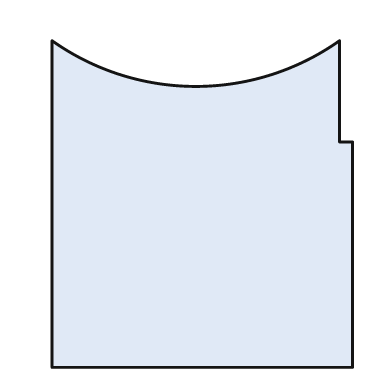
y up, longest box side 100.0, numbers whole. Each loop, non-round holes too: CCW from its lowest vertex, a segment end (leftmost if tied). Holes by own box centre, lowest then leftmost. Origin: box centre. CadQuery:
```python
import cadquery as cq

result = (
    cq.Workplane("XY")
    .moveTo(-46.0, -50.0)
    .lineTo(46.0, -50.0)
    .lineTo(46.0, 19.0)
    .lineTo(42.0, 19.0)
    .lineTo(42.0, 50.0)
    .threePointArc((-2.0, 36.0), (-46.0, 50.0))
    .close()
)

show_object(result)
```